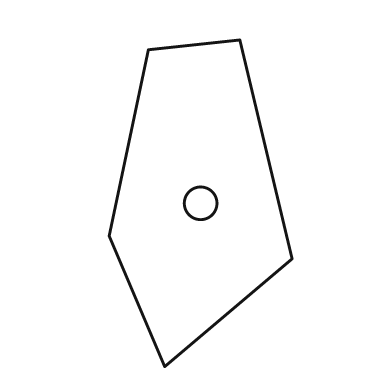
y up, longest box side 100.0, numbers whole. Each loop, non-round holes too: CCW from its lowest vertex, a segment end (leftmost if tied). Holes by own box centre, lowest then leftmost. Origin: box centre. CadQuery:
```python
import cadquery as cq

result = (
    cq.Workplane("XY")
    .moveTo(-11.0, -50.0)
    .lineTo(28.0, -17.0)
    .lineTo(12.0, 50.0)
    .lineTo(-16.0, 47.0)
    .lineTo(-28.0, -10.0)
    .close()
    .moveTo(0.0, 0.0)
    .circle(5.0)
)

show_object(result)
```